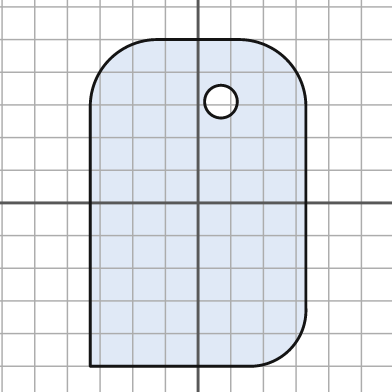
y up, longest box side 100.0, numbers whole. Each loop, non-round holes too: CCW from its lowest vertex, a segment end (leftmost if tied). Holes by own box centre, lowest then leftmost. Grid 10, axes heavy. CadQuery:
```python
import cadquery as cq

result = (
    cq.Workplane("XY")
    .moveTo(-33.0, -50.0)
    .lineTo(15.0, -50.0)
    .threePointArc((28.0, -45.0), (33.0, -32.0))
    .lineTo(33.0, 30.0)
    .threePointArc((27.0, 44.0), (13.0, 50.0))
    .lineTo(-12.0, 50.0)
    .threePointArc((-27.0, 44.0), (-33.0, 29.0))
    .close()
    .moveTo(7.0, 31.0)
    .circle(5.0)
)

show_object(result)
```